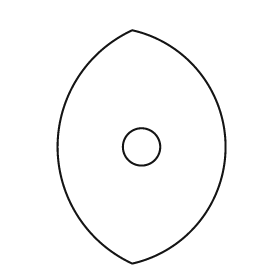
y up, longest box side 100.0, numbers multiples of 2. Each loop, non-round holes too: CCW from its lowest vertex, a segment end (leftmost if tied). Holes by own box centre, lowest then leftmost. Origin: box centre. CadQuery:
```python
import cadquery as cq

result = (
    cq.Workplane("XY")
    .moveTo(-4.0, -50.0)
    .threePointArc((36.0, 0.0), (-4.0, 50.0))
    .threePointArc((-36.0, 0.0), (-4.0, -50.0))
    .close()
    .moveTo(0.0, 0.0)
    .circle(8.0)
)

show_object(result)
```